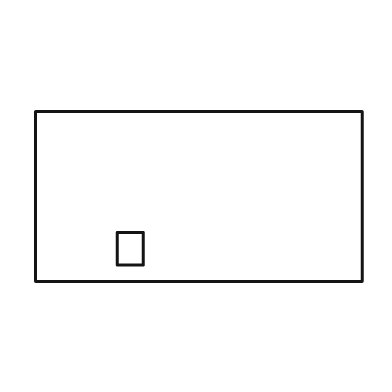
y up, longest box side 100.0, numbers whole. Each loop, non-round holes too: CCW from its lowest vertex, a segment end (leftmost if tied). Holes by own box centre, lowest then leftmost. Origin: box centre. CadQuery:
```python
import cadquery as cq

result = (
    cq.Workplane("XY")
    .moveTo(-50.0, -26.0)
    .lineTo(50.0, -26.0)
    .lineTo(50.0, 26.0)
    .lineTo(-50.0, 26.0)
    .close()
    .moveTo(-25.0, -21.0)
    .lineTo(-17.0, -21.0)
    .lineTo(-17.0, -11.0)
    .lineTo(-25.0, -11.0)
    .close()
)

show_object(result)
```